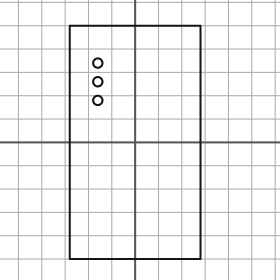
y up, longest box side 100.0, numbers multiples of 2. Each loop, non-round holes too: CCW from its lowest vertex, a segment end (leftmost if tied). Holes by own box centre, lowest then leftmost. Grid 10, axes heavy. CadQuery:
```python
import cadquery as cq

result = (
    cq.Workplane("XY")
    .moveTo(-28.0, -50.0)
    .lineTo(28.0, -50.0)
    .lineTo(28.0, 50.0)
    .lineTo(-28.0, 50.0)
    .close()
    .moveTo(-16.0, 18.0)
    .circle(2.0)
    .moveTo(-16.0, 26.0)
    .circle(2.0)
    .moveTo(-16.0, 34.0)
    .circle(2.0)
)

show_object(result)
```